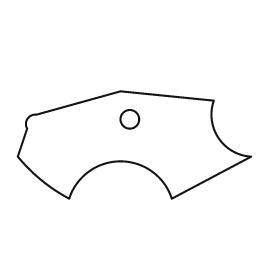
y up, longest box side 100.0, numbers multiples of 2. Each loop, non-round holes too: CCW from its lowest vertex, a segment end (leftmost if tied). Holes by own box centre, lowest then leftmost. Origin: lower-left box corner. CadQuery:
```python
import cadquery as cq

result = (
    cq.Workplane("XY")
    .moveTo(22.0, 0.0)
    .threePointArc((44.0, 16.0), (66.0, 0.0))
    .lineTo(100.0, 18.0)
    .threePointArc((86.0, 26.0), (84.0, 42.0))
    .lineTo(44.0, 46.0)
    .lineTo(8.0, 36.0)
    .threePointArc((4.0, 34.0), (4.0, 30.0))
    .lineTo(0.0, 18.0)
    .threePointArc((10.0, 8.0), (22.0, 0.0))
    .close()
    .moveTo(48.0, 34.0)
    .circle(4.0)
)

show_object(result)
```